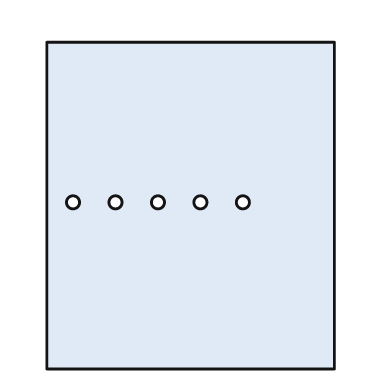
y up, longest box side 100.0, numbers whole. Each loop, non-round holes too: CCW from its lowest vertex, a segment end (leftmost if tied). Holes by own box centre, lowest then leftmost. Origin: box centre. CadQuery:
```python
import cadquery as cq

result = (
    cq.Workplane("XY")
    .moveTo(-44.0, -50.0)
    .lineTo(44.0, -50.0)
    .lineTo(44.0, 50.0)
    .lineTo(-44.0, 50.0)
    .close()
    .moveTo(-36.0, 1.0)
    .circle(2.0)
    .moveTo(-23.0, 1.0)
    .circle(2.0)
    .moveTo(-10.0, 1.0)
    .circle(2.0)
    .moveTo(3.0, 1.0)
    .circle(2.0)
    .moveTo(16.0, 1.0)
    .circle(2.0)
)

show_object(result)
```